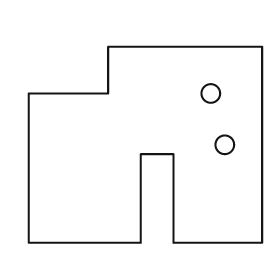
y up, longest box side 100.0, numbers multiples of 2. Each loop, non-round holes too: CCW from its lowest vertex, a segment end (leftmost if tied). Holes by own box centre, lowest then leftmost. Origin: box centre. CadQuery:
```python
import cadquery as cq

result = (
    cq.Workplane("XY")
    .moveTo(-50.0, -42.0)
    .lineTo(-2.0, -42.0)
    .lineTo(-2.0, -4.0)
    .lineTo(12.0, -4.0)
    .lineTo(12.0, -42.0)
    .lineTo(50.0, -42.0)
    .lineTo(50.0, 42.0)
    .lineTo(-16.0, 42.0)
    .lineTo(-16.0, 22.0)
    .lineTo(-50.0, 22.0)
    .close()
    .moveTo(34.0, 0.0)
    .circle(4.0)
    .moveTo(28.0, 22.0)
    .circle(4.0)
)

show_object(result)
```